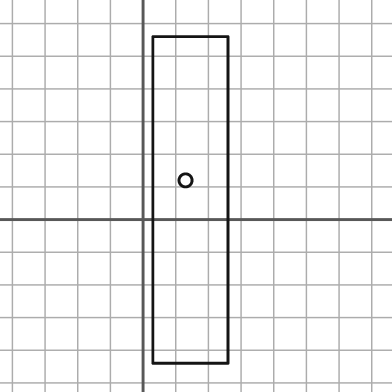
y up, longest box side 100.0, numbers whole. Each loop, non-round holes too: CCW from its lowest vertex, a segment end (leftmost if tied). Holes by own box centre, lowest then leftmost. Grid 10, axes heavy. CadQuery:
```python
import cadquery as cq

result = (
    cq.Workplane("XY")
    .moveTo(3.0, -44.0)
    .lineTo(26.0, -44.0)
    .lineTo(26.0, 56.0)
    .lineTo(3.0, 56.0)
    .close()
    .moveTo(13.0, 12.0)
    .circle(2.0)
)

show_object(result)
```